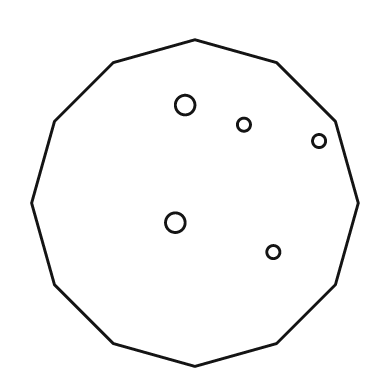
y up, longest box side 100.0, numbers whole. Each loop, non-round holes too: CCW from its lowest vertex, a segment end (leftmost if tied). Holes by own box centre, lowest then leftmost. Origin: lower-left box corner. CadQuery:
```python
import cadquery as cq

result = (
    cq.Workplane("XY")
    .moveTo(50.0, 0.0)
    .lineTo(75.0, 7.0)
    .lineTo(93.0, 25.0)
    .lineTo(100.0, 50.0)
    .lineTo(93.0, 75.0)
    .lineTo(75.0, 93.0)
    .lineTo(50.0, 100.0)
    .lineTo(25.0, 93.0)
    .lineTo(7.0, 75.0)
    .lineTo(0.0, 50.0)
    .lineTo(7.0, 25.0)
    .lineTo(25.0, 7.0)
    .close()
    .moveTo(74.0, 35.0)
    .circle(2.0)
    .moveTo(44.0, 44.0)
    .circle(3.0)
    .moveTo(88.0, 69.0)
    .circle(2.0)
    .moveTo(65.0, 74.0)
    .circle(2.0)
    .moveTo(47.0, 80.0)
    .circle(3.0)
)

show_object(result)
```